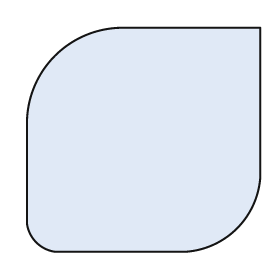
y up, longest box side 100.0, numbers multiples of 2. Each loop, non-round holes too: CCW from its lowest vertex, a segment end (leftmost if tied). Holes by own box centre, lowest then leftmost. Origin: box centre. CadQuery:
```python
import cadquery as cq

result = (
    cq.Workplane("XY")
    .moveTo(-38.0, -48.0)
    .lineTo(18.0, -48.0)
    .threePointArc((40.0, -38.0), (50.0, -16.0))
    .lineTo(50.0, 48.0)
    .lineTo(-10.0, 48.0)
    .threePointArc((-38.0, 36.0), (-50.0, 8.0))
    .lineTo(-50.0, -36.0)
    .threePointArc((-46.0, -44.0), (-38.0, -48.0))
    .close()
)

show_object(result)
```